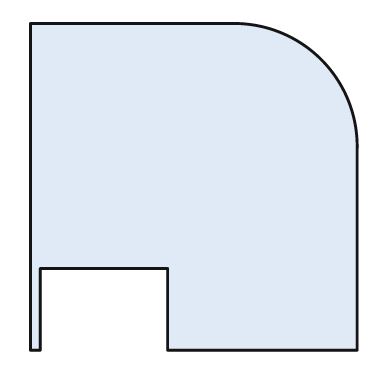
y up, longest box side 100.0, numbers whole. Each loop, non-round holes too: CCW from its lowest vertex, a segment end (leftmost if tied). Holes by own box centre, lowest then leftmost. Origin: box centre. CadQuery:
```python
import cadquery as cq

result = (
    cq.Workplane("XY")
    .moveTo(-50.0, -50.0)
    .lineTo(-47.0, -50.0)
    .lineTo(-47.0, -25.0)
    .lineTo(-8.0, -25.0)
    .lineTo(-8.0, -50.0)
    .lineTo(50.0, -50.0)
    .lineTo(50.0, 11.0)
    .threePointArc((39.0, 39.0), (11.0, 50.0))
    .lineTo(-50.0, 50.0)
    .close()
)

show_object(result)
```